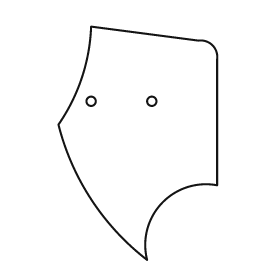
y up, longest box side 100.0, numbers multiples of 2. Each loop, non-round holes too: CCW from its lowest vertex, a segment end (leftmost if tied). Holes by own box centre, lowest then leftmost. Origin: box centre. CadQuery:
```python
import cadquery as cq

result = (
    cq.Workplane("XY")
    .moveTo(4.0, -50.0)
    .threePointArc((10.0, -26.0), (34.0, -18.0))
    .lineTo(34.0, 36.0)
    .threePointArc((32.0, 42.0), (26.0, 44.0))
    .lineTo(-20.0, 50.0)
    .threePointArc((-24.0, 28.0), (-34.0, 8.0))
    .threePointArc((-20.0, -24.0), (4.0, -50.0))
    .close()
    .moveTo(-20.0, 18.0)
    .circle(2.0)
    .moveTo(6.0, 18.0)
    .circle(2.0)
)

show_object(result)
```